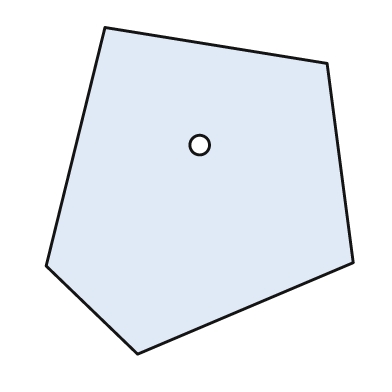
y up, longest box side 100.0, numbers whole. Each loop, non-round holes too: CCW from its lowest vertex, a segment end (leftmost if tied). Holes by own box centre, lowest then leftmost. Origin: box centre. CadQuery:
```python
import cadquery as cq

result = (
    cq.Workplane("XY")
    .moveTo(-19.0, -50.0)
    .lineTo(47.0, -22.0)
    .lineTo(39.0, 39.0)
    .lineTo(-29.0, 50.0)
    .lineTo(-47.0, -23.0)
    .close()
    .moveTo(0.0, 14.0)
    .circle(3.0)
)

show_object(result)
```